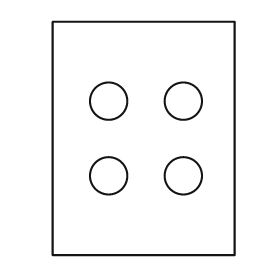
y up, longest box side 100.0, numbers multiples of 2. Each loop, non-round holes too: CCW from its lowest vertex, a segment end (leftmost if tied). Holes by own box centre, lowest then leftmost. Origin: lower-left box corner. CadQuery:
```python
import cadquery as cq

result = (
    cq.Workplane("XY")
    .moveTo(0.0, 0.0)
    .lineTo(78.0, 0.0)
    .lineTo(78.0, 100.0)
    .lineTo(0.0, 100.0)
    .close()
    .moveTo(24.0, 34.0)
    .circle(8.0)
    .moveTo(56.0, 34.0)
    .circle(8.0)
    .moveTo(24.0, 66.0)
    .circle(8.0)
    .moveTo(56.0, 66.0)
    .circle(8.0)
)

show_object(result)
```